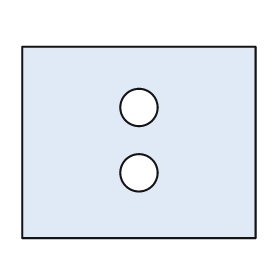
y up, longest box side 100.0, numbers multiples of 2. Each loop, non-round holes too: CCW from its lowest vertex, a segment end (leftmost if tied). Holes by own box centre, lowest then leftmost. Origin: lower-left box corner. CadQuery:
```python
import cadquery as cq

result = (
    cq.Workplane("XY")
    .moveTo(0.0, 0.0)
    .lineTo(100.0, 0.0)
    .lineTo(100.0, 82.0)
    .lineTo(0.0, 82.0)
    .close()
    .moveTo(50.0, 28.0)
    .circle(8.0)
    .moveTo(50.0, 56.0)
    .circle(8.0)
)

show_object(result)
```